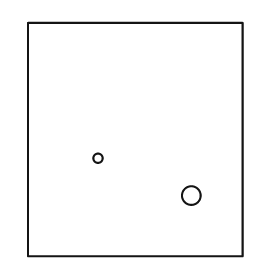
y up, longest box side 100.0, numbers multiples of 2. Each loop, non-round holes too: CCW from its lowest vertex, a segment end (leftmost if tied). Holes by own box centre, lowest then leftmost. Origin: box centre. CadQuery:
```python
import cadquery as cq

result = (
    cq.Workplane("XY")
    .moveTo(-46.0, -50.0)
    .lineTo(46.0, -50.0)
    .lineTo(46.0, 50.0)
    .lineTo(-46.0, 50.0)
    .close()
    .moveTo(24.0, -24.0)
    .circle(4.0)
    .moveTo(-16.0, -8.0)
    .circle(2.0)
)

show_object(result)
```